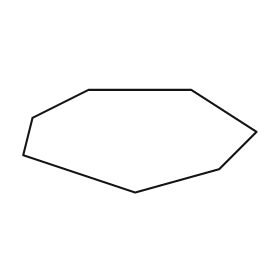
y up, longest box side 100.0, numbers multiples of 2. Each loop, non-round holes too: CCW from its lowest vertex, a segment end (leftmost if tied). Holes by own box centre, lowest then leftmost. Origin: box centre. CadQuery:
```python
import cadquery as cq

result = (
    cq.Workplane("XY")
    .moveTo(-2.0, -22.0)
    .lineTo(34.0, -12.0)
    .lineTo(50.0, 4.0)
    .lineTo(22.0, 22.0)
    .lineTo(-22.0, 22.0)
    .lineTo(-46.0, 10.0)
    .lineTo(-50.0, -6.0)
    .close()
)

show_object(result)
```